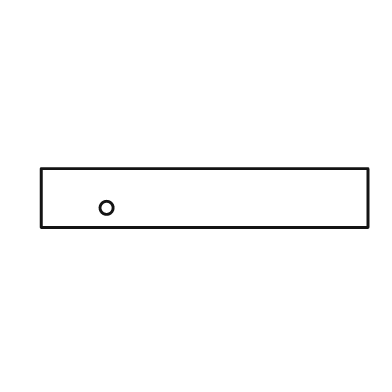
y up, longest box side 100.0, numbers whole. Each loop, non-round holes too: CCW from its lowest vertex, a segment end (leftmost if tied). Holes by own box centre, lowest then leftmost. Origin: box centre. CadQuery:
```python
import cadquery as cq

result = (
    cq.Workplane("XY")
    .moveTo(-50.0, -9.0)
    .lineTo(50.0, -9.0)
    .lineTo(50.0, 9.0)
    .lineTo(-50.0, 9.0)
    .close()
    .moveTo(-30.0, -3.0)
    .circle(2.0)
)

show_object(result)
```